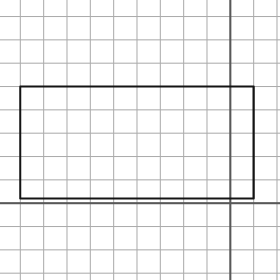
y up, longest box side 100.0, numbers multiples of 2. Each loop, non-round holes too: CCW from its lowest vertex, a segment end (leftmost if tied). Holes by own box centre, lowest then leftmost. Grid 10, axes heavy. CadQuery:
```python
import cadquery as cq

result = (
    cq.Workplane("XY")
    .moveTo(-90.0, 2.0)
    .lineTo(10.0, 2.0)
    .lineTo(10.0, 50.0)
    .lineTo(-90.0, 50.0)
    .close()
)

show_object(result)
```